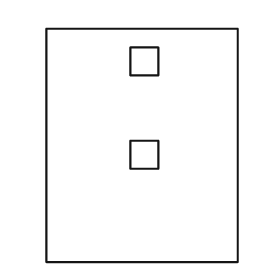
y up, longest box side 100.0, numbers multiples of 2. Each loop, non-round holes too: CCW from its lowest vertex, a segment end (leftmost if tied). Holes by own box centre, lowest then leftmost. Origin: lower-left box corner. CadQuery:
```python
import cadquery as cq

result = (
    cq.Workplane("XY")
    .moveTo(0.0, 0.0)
    .lineTo(82.0, 0.0)
    .lineTo(82.0, 100.0)
    .lineTo(0.0, 100.0)
    .close()
    .moveTo(36.0, 40.0)
    .lineTo(48.0, 40.0)
    .lineTo(48.0, 52.0)
    .lineTo(36.0, 52.0)
    .close()
    .moveTo(36.0, 80.0)
    .lineTo(48.0, 80.0)
    .lineTo(48.0, 92.0)
    .lineTo(36.0, 92.0)
    .close()
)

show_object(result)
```